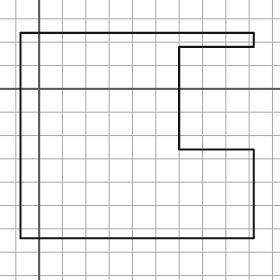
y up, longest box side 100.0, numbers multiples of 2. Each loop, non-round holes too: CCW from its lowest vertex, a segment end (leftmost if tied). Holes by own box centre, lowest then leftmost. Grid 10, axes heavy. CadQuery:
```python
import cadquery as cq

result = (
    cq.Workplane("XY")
    .moveTo(-8.0, -64.0)
    .lineTo(92.0, -64.0)
    .lineTo(92.0, -26.0)
    .lineTo(60.0, -26.0)
    .lineTo(60.0, 18.0)
    .lineTo(92.0, 18.0)
    .lineTo(92.0, 24.0)
    .lineTo(-8.0, 24.0)
    .close()
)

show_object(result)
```